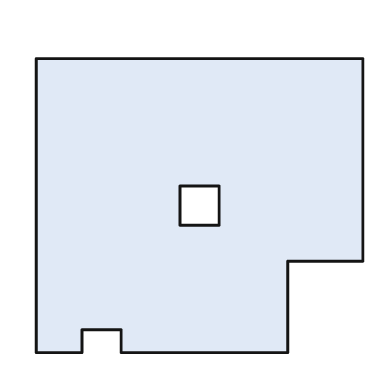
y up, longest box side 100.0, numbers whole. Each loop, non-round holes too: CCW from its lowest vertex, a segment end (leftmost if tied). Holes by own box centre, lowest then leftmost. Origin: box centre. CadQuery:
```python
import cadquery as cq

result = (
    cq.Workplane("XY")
    .moveTo(-50.0, -45.0)
    .lineTo(-36.0, -45.0)
    .lineTo(-36.0, -38.0)
    .lineTo(-24.0, -38.0)
    .lineTo(-24.0, -45.0)
    .lineTo(27.0, -45.0)
    .lineTo(27.0, -17.0)
    .lineTo(50.0, -17.0)
    .lineTo(50.0, 45.0)
    .lineTo(-50.0, 45.0)
    .close()
    .moveTo(-6.0, -6.0)
    .lineTo(6.0, -6.0)
    .lineTo(6.0, 6.0)
    .lineTo(-6.0, 6.0)
    .close()
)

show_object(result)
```